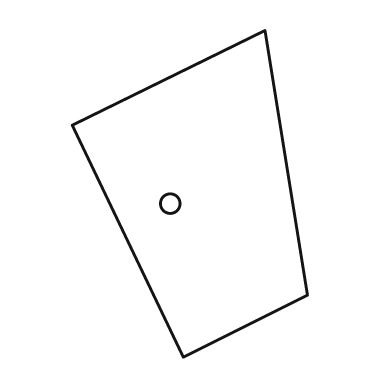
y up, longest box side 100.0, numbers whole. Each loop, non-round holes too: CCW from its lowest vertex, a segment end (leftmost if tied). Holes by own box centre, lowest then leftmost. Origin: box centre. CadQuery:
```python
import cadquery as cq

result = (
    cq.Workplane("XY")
    .moveTo(-2.0, -50.0)
    .lineTo(36.0, -31.0)
    .lineTo(23.0, 50.0)
    .lineTo(-36.0, 21.0)
    .close()
    .moveTo(-6.0, -3.0)
    .circle(3.0)
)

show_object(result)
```